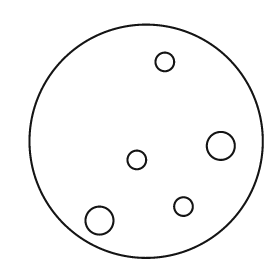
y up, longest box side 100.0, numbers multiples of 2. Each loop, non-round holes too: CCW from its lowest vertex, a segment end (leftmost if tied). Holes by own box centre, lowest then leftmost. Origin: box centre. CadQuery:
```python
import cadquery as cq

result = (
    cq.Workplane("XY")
    .moveTo(0.0, 0.0)
    .circle(50.0)
    .moveTo(-20.0, -34.0)
    .circle(6.0)
    .moveTo(16.0, -28.0)
    .circle(4.0)
    .moveTo(-4.0, -8.0)
    .circle(4.0)
    .moveTo(32.0, -2.0)
    .circle(6.0)
    .moveTo(8.0, 34.0)
    .circle(4.0)
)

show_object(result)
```